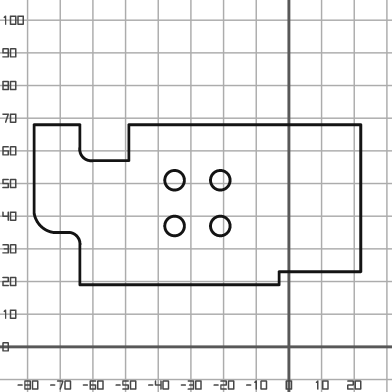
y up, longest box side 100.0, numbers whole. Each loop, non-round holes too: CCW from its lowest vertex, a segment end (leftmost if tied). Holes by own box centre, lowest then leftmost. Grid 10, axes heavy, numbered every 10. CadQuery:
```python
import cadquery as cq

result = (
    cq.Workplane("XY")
    .moveTo(-64.0, 19.0)
    .lineTo(-3.0, 19.0)
    .lineTo(-3.0, 23.0)
    .lineTo(22.0, 23.0)
    .lineTo(22.0, 68.0)
    .lineTo(-49.0, 68.0)
    .lineTo(-49.0, 57.0)
    .lineTo(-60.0, 57.0)
    .threePointArc((-63.0, 58.0), (-64.0, 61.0))
    .lineTo(-64.0, 68.0)
    .lineTo(-78.0, 68.0)
    .lineTo(-78.0, 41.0)
    .threePointArc((-76.0, 37.0), (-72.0, 35.0))
    .lineTo(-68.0, 35.0)
    .threePointArc((-65.0, 34.0), (-64.0, 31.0))
    .close()
    .moveTo(-35.0, 37.0)
    .circle(3.0)
    .moveTo(-21.0, 37.0)
    .circle(3.0)
    .moveTo(-35.0, 51.0)
    .circle(3.0)
    .moveTo(-21.0, 51.0)
    .circle(3.0)
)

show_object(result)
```